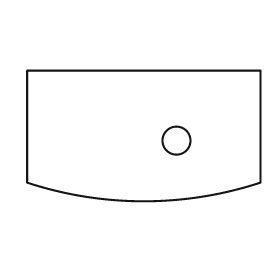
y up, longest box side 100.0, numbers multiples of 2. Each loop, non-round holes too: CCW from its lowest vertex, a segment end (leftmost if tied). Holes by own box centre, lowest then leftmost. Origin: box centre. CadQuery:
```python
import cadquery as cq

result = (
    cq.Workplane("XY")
    .moveTo(-50.0, -20.0)
    .threePointArc((0.0, -28.0), (50.0, -20.0))
    .lineTo(50.0, 28.0)
    .lineTo(-50.0, 28.0)
    .close()
    .moveTo(14.0, -2.0)
    .circle(6.0)
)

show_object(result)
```